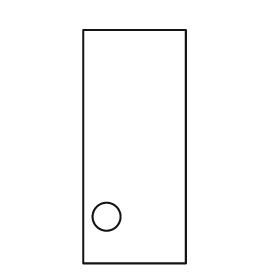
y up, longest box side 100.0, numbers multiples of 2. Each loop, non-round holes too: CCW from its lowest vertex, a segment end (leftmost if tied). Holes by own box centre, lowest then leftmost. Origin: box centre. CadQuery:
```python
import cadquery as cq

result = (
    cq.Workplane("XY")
    .moveTo(-22.0, -50.0)
    .lineTo(22.0, -50.0)
    .lineTo(22.0, 50.0)
    .lineTo(-22.0, 50.0)
    .close()
    .moveTo(-12.0, -30.0)
    .circle(6.0)
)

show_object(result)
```